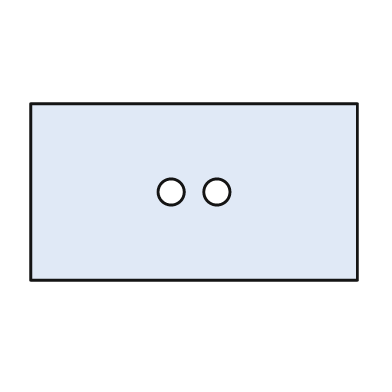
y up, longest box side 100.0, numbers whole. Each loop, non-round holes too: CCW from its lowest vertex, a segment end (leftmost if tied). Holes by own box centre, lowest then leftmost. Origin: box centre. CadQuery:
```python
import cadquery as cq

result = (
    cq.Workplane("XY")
    .moveTo(-50.0, -27.0)
    .lineTo(50.0, -27.0)
    .lineTo(50.0, 27.0)
    .lineTo(-50.0, 27.0)
    .close()
    .moveTo(-7.0, 0.0)
    .circle(4.0)
    .moveTo(7.0, 0.0)
    .circle(4.0)
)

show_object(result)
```